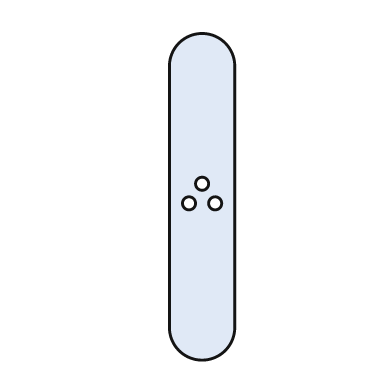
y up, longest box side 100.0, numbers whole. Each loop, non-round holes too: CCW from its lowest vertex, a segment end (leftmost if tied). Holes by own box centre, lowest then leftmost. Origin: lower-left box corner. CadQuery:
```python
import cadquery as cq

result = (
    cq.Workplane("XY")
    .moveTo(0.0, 10.0)
    .threePointArc((10.0, 0.0), (20.0, 10.0))
    .lineTo(20.0, 90.0)
    .threePointArc((10.0, 100.0), (0.0, 90.0))
    .close()
    .moveTo(6.0, 48.0)
    .circle(2.0)
    .moveTo(14.0, 48.0)
    .circle(2.0)
    .moveTo(10.0, 54.0)
    .circle(2.0)
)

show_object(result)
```